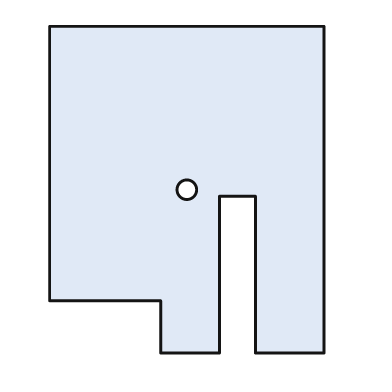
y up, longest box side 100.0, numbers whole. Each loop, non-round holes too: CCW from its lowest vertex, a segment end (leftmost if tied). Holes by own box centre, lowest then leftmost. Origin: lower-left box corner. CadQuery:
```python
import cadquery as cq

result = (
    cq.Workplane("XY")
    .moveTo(34.0, 0.0)
    .lineTo(52.0, 0.0)
    .lineTo(52.0, 48.0)
    .lineTo(63.0, 48.0)
    .lineTo(63.0, 0.0)
    .lineTo(84.0, 0.0)
    .lineTo(84.0, 100.0)
    .lineTo(0.0, 100.0)
    .lineTo(0.0, 16.0)
    .lineTo(34.0, 16.0)
    .close()
    .moveTo(42.0, 50.0)
    .circle(3.0)
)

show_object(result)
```